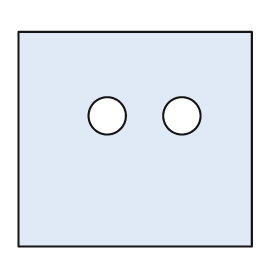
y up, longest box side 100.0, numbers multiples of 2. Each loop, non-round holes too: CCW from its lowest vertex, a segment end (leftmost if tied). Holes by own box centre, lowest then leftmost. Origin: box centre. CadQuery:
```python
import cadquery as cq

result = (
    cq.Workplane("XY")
    .moveTo(-50.0, -46.0)
    .lineTo(50.0, -46.0)
    .lineTo(50.0, 46.0)
    .lineTo(-50.0, 46.0)
    .close()
    .moveTo(-12.0, 10.0)
    .circle(8.0)
    .moveTo(20.0, 10.0)
    .circle(8.0)
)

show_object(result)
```